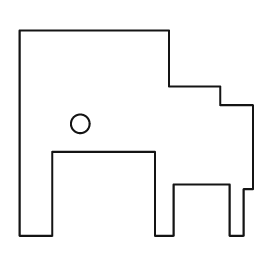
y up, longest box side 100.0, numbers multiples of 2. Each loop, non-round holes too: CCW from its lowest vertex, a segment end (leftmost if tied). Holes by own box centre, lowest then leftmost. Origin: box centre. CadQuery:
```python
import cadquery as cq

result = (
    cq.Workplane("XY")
    .moveTo(-50.0, -44.0)
    .lineTo(-36.0, -44.0)
    .lineTo(-36.0, -8.0)
    .lineTo(8.0, -8.0)
    .lineTo(8.0, -44.0)
    .lineTo(16.0, -44.0)
    .lineTo(16.0, -22.0)
    .lineTo(40.0, -22.0)
    .lineTo(40.0, -44.0)
    .lineTo(46.0, -44.0)
    .lineTo(46.0, -24.0)
    .lineTo(50.0, -24.0)
    .lineTo(50.0, 12.0)
    .lineTo(36.0, 12.0)
    .lineTo(36.0, 20.0)
    .lineTo(14.0, 20.0)
    .lineTo(14.0, 44.0)
    .lineTo(-50.0, 44.0)
    .close()
    .moveTo(-24.0, 4.0)
    .circle(4.0)
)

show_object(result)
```